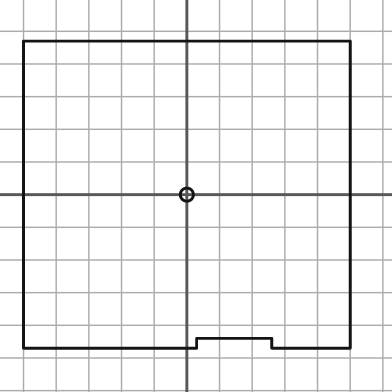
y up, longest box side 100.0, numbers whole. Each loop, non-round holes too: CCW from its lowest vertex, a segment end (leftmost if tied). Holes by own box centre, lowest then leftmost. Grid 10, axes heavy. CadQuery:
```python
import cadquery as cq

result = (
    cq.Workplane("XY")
    .moveTo(-50.0, -47.0)
    .lineTo(3.0, -47.0)
    .lineTo(3.0, -44.0)
    .lineTo(26.0, -44.0)
    .lineTo(26.0, -47.0)
    .lineTo(50.0, -47.0)
    .lineTo(50.0, 47.0)
    .lineTo(-50.0, 47.0)
    .close()
    .moveTo(0.0, 0.0)
    .circle(2.0)
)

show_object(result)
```